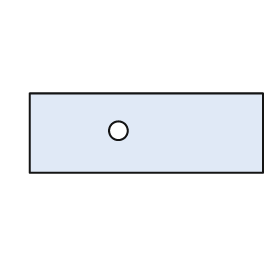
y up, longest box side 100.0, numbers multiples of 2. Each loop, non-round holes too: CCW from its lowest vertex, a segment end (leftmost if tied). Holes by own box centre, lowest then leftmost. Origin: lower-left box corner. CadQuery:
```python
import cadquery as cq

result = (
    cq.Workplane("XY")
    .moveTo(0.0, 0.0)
    .lineTo(100.0, 0.0)
    .lineTo(100.0, 34.0)
    .lineTo(0.0, 34.0)
    .close()
    .moveTo(38.0, 18.0)
    .circle(4.0)
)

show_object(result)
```